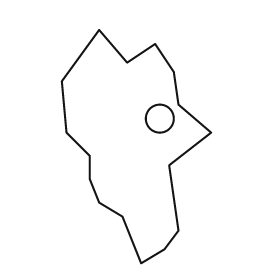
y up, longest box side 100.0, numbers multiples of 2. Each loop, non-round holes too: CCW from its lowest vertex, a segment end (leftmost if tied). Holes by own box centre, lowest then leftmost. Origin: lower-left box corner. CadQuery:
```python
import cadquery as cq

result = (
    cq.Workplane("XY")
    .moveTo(34.0, 0.0)
    .lineTo(44.0, 6.0)
    .lineTo(50.0, 14.0)
    .lineTo(46.0, 42.0)
    .lineTo(64.0, 56.0)
    .lineTo(50.0, 68.0)
    .lineTo(48.0, 82.0)
    .lineTo(40.0, 94.0)
    .lineTo(28.0, 86.0)
    .lineTo(16.0, 100.0)
    .lineTo(0.0, 78.0)
    .lineTo(2.0, 56.0)
    .lineTo(12.0, 46.0)
    .lineTo(12.0, 36.0)
    .lineTo(16.0, 26.0)
    .lineTo(26.0, 20.0)
    .close()
    .moveTo(42.0, 62.0)
    .circle(6.0)
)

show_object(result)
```